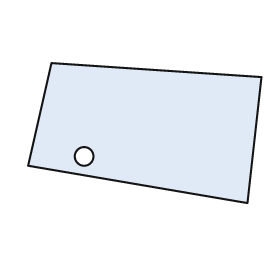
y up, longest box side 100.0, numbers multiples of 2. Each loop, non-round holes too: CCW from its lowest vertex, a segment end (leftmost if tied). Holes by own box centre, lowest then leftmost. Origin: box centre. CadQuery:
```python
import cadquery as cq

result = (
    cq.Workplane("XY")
    .moveTo(44.0, -30.0)
    .lineTo(50.0, 24.0)
    .lineTo(-40.0, 30.0)
    .lineTo(-50.0, -14.0)
    .close()
    .moveTo(-26.0, -10.0)
    .circle(4.0)
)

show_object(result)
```